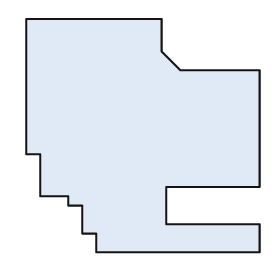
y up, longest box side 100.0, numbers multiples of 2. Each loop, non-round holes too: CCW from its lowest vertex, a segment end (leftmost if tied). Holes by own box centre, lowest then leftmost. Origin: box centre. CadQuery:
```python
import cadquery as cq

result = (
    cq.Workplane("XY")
    .moveTo(-20.0, -50.0)
    .lineTo(50.0, -50.0)
    .lineTo(50.0, -38.0)
    .lineTo(10.0, -38.0)
    .lineTo(10.0, -22.0)
    .lineTo(50.0, -22.0)
    .lineTo(50.0, 28.0)
    .lineTo(16.0, 28.0)
    .lineTo(8.0, 36.0)
    .lineTo(8.0, 50.0)
    .lineTo(-50.0, 50.0)
    .lineTo(-50.0, -8.0)
    .lineTo(-44.0, -8.0)
    .lineTo(-44.0, -26.0)
    .lineTo(-32.0, -26.0)
    .lineTo(-32.0, -30.0)
    .lineTo(-26.0, -30.0)
    .lineTo(-26.0, -42.0)
    .lineTo(-20.0, -42.0)
    .close()
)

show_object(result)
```